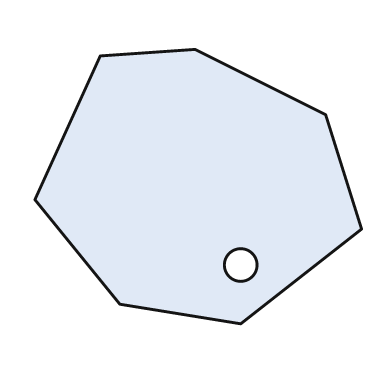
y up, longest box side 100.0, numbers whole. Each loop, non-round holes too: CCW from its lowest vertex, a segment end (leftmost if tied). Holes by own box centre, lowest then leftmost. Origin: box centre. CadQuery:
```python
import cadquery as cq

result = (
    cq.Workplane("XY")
    .moveTo(13.0, -42.0)
    .lineTo(50.0, -13.0)
    .lineTo(39.0, 22.0)
    .lineTo(-1.0, 42.0)
    .lineTo(-30.0, 40.0)
    .lineTo(-50.0, -4.0)
    .lineTo(-24.0, -36.0)
    .close()
    .moveTo(13.0, -24.0)
    .circle(5.0)
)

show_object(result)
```